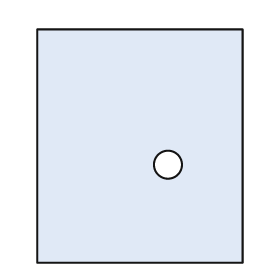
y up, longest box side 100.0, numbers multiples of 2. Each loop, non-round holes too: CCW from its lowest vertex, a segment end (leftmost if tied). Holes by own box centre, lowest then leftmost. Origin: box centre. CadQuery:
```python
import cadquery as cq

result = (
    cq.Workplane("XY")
    .moveTo(-44.0, -50.0)
    .lineTo(44.0, -50.0)
    .lineTo(44.0, 50.0)
    .lineTo(-44.0, 50.0)
    .close()
    .moveTo(12.0, -8.0)
    .circle(6.0)
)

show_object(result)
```